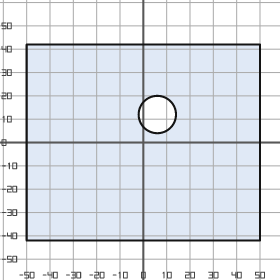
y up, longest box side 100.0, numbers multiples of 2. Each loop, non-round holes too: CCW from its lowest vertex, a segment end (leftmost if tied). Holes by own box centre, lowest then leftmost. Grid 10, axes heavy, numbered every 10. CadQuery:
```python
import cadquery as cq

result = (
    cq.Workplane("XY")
    .moveTo(-50.0, -42.0)
    .lineTo(50.0, -42.0)
    .lineTo(50.0, 42.0)
    .lineTo(-50.0, 42.0)
    .close()
    .moveTo(6.0, 12.0)
    .circle(8.0)
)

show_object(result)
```